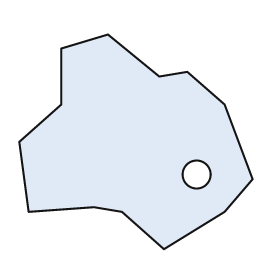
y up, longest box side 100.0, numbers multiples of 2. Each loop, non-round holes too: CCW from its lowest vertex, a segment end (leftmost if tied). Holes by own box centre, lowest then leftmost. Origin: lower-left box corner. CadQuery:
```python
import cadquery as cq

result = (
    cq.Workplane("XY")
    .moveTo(62.0, 0.0)
    .lineTo(88.0, 16.0)
    .lineTo(100.0, 30.0)
    .lineTo(88.0, 62.0)
    .lineTo(72.0, 76.0)
    .lineTo(60.0, 74.0)
    .lineTo(38.0, 92.0)
    .lineTo(18.0, 86.0)
    .lineTo(18.0, 62.0)
    .lineTo(0.0, 46.0)
    .lineTo(4.0, 16.0)
    .lineTo(32.0, 18.0)
    .lineTo(44.0, 16.0)
    .close()
    .moveTo(76.0, 32.0)
    .circle(6.0)
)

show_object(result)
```